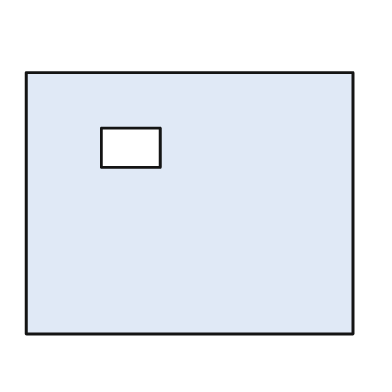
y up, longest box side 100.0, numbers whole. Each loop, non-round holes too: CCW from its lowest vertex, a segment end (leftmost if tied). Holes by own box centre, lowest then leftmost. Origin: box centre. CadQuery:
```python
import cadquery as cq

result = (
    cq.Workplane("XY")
    .moveTo(-50.0, -40.0)
    .lineTo(50.0, -40.0)
    .lineTo(50.0, 40.0)
    .lineTo(-50.0, 40.0)
    .close()
    .moveTo(-27.0, 11.0)
    .lineTo(-9.0, 11.0)
    .lineTo(-9.0, 23.0)
    .lineTo(-27.0, 23.0)
    .close()
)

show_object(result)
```